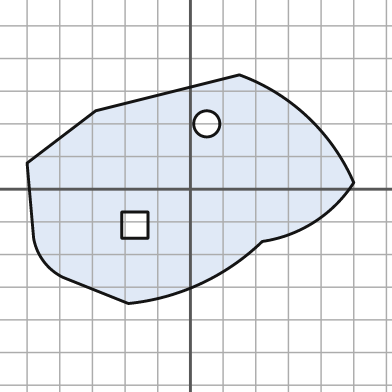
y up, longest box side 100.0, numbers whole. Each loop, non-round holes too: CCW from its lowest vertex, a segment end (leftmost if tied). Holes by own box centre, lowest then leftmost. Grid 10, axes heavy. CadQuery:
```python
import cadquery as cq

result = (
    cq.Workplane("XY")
    .moveTo(-19.0, -35.0)
    .threePointArc((3.0, -29.0), (22.0, -16.0))
    .threePointArc((38.0, -10.0), (50.0, 2.0))
    .threePointArc((36.0, 22.0), (15.0, 35.0))
    .lineTo(-29.0, 24.0)
    .lineTo(-50.0, 8.0)
    .lineTo(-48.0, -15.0)
    .threePointArc((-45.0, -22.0), (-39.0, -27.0))
    .close()
    .moveTo(-21.0, -15.0)
    .lineTo(-13.0, -15.0)
    .lineTo(-13.0, -7.0)
    .lineTo(-21.0, -7.0)
    .close()
    .moveTo(5.0, 20.0)
    .circle(4.0)
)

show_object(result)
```